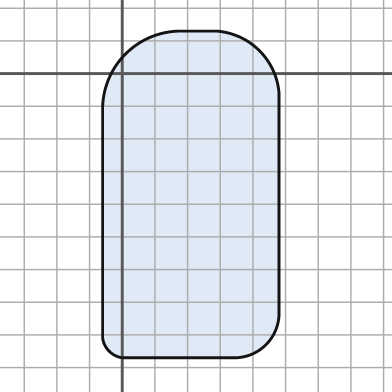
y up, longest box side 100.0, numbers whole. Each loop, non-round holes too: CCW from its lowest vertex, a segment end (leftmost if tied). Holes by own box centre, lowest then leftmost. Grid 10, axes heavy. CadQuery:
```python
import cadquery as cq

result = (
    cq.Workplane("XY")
    .moveTo(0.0, -87.0)
    .lineTo(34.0, -87.0)
    .threePointArc((44.0, -83.0), (48.0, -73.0))
    .lineTo(48.0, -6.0)
    .threePointArc((42.0, 7.0), (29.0, 13.0))
    .lineTo(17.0, 13.0)
    .threePointArc((1.0, 6.0), (-6.0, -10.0))
    .lineTo(-6.0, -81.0)
    .threePointArc((-4.0, -85.0), (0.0, -87.0))
    .close()
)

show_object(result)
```